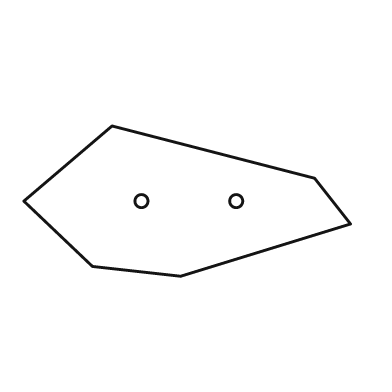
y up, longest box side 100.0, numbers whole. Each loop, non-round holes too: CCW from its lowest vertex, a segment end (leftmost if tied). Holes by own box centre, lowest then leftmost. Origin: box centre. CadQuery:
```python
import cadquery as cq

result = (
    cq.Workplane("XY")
    .moveTo(-2.0, -23.0)
    .lineTo(50.0, -7.0)
    .lineTo(39.0, 7.0)
    .lineTo(-23.0, 23.0)
    .lineTo(-50.0, 0.0)
    .lineTo(-29.0, -20.0)
    .close()
    .moveTo(-14.0, 0.0)
    .circle(2.0)
    .moveTo(15.0, 0.0)
    .circle(2.0)
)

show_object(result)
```